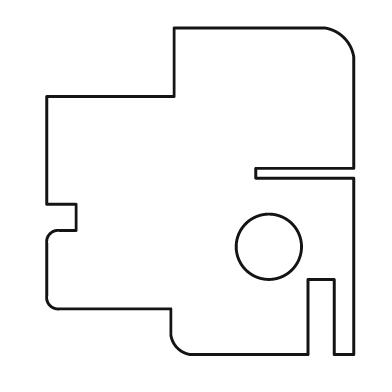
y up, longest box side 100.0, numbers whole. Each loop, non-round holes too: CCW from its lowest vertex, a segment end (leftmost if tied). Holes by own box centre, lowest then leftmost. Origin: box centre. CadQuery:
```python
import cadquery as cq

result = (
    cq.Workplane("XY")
    .moveTo(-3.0, -50.0)
    .lineTo(33.0, -50.0)
    .lineTo(33.0, -27.0)
    .lineTo(41.0, -27.0)
    .lineTo(41.0, -50.0)
    .lineTo(47.0, -50.0)
    .lineTo(47.0, 4.0)
    .lineTo(17.0, 4.0)
    .lineTo(17.0, 7.0)
    .lineTo(47.0, 7.0)
    .lineTo(47.0, 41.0)
    .threePointArc((44.0, 47.0), (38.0, 50.0))
    .lineTo(-8.0, 50.0)
    .lineTo(-8.0, 29.0)
    .lineTo(-47.0, 29.0)
    .lineTo(-47.0, -4.0)
    .lineTo(-38.0, -4.0)
    .lineTo(-38.0, -12.0)
    .lineTo(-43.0, -12.0)
    .threePointArc((-46.0, -13.0), (-47.0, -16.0))
    .lineTo(-47.0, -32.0)
    .threePointArc((-46.0, -35.0), (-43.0, -36.0))
    .lineTo(-9.0, -36.0)
    .lineTo(-9.0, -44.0)
    .threePointArc((-7.0, -48.0), (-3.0, -50.0))
    .close()
    .moveTo(21.0, -17.0)
    .circle(10.0)
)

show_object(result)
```